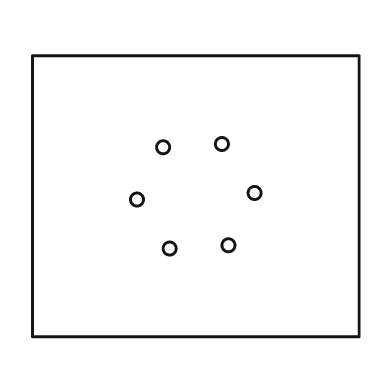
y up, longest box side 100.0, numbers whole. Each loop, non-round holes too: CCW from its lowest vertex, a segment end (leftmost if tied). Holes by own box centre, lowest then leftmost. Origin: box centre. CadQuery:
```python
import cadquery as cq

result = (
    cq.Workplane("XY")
    .moveTo(-50.0, -43.0)
    .lineTo(50.0, -43.0)
    .lineTo(50.0, 43.0)
    .lineTo(-50.0, 43.0)
    .close()
    .moveTo(-8.0, -16.0)
    .circle(2.0)
    .moveTo(10.0, -15.0)
    .circle(2.0)
    .moveTo(-18.0, -1.0)
    .circle(2.0)
    .moveTo(18.0, 1.0)
    .circle(2.0)
    .moveTo(-10.0, 15.0)
    .circle(2.0)
    .moveTo(8.0, 16.0)
    .circle(2.0)
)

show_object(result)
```